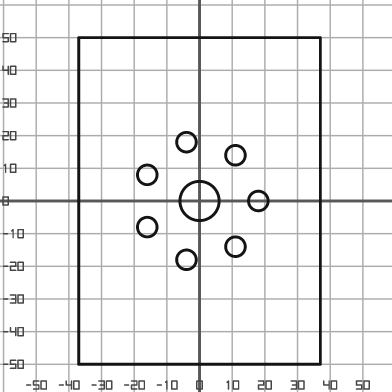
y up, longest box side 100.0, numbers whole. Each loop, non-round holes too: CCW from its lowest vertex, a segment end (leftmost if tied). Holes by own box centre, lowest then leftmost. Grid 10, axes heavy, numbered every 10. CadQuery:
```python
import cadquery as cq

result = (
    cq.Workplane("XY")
    .moveTo(-37.0, -50.0)
    .lineTo(37.0, -50.0)
    .lineTo(37.0, 50.0)
    .lineTo(-37.0, 50.0)
    .close()
    .moveTo(-4.0, -18.0)
    .circle(3.0)
    .moveTo(11.0, -14.0)
    .circle(3.0)
    .moveTo(-16.0, -8.0)
    .circle(3.0)
    .moveTo(0.0, 0.0)
    .circle(6.0)
    .moveTo(18.0, 0.0)
    .circle(3.0)
    .moveTo(-16.0, 8.0)
    .circle(3.0)
    .moveTo(11.0, 14.0)
    .circle(3.0)
    .moveTo(-4.0, 18.0)
    .circle(3.0)
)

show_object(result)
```